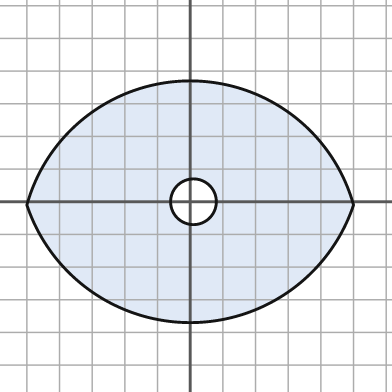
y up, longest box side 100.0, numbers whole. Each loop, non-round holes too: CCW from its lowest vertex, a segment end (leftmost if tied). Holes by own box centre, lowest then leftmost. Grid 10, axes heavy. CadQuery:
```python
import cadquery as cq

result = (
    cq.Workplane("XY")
    .moveTo(-50.0, -1.0)
    .threePointArc((0.0, -37.0), (50.0, -1.0))
    .threePointArc((0.0, 37.0), (-50.0, -1.0))
    .close()
    .moveTo(1.0, 0.0)
    .circle(7.0)
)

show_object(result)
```